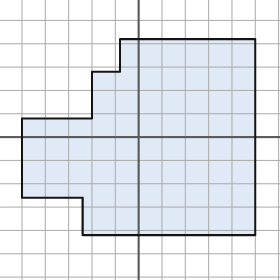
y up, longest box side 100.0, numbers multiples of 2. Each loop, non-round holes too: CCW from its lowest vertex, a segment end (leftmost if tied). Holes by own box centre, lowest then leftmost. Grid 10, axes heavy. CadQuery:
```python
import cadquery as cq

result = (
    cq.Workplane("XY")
    .moveTo(-24.0, -42.0)
    .lineTo(50.0, -42.0)
    .lineTo(50.0, 42.0)
    .lineTo(-8.0, 42.0)
    .lineTo(-8.0, 28.0)
    .lineTo(-20.0, 28.0)
    .lineTo(-20.0, 8.0)
    .lineTo(-50.0, 8.0)
    .lineTo(-50.0, -26.0)
    .lineTo(-24.0, -26.0)
    .close()
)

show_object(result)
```